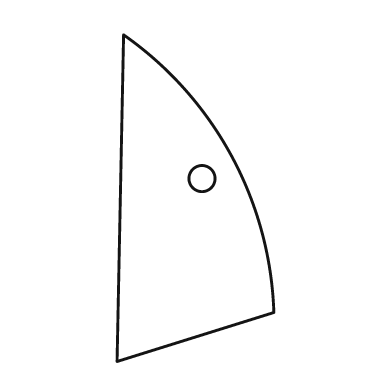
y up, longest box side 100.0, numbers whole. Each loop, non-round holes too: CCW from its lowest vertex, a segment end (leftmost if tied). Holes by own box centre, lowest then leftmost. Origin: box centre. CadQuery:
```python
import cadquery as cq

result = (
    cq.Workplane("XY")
    .moveTo(-24.0, -50.0)
    .lineTo(24.0, -35.0)
    .threePointArc((11.0, 13.0), (-22.0, 50.0))
    .close()
    .moveTo(2.0, 6.0)
    .circle(4.0)
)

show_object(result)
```